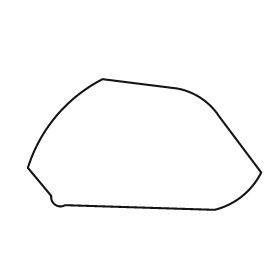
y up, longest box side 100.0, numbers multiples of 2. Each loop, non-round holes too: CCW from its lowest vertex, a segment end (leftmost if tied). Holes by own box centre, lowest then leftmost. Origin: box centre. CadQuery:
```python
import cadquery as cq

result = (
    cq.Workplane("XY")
    .moveTo(30.0, -28.0)
    .threePointArc((42.0, -22.0), (50.0, -12.0))
    .lineTo(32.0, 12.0)
    .threePointArc((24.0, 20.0), (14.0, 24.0))
    .lineTo(-18.0, 28.0)
    .threePointArc((-38.0, 12.0), (-50.0, -10.0))
    .lineTo(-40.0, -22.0)
    .threePointArc((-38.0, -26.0), (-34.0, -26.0))
    .close()
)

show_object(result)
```